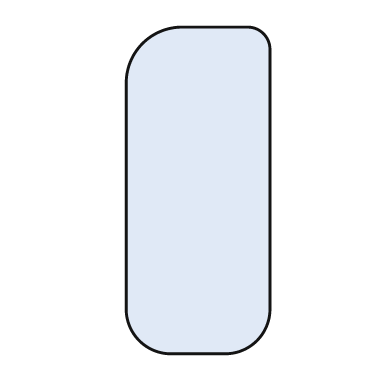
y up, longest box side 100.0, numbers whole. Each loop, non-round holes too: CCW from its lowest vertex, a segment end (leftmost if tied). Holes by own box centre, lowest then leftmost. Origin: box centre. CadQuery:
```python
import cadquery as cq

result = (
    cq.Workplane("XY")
    .moveTo(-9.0, -50.0)
    .lineTo(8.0, -50.0)
    .threePointArc((18.0, -46.0), (22.0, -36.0))
    .lineTo(22.0, 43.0)
    .threePointArc((20.0, 48.0), (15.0, 50.0))
    .lineTo(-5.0, 50.0)
    .threePointArc((-17.0, 45.0), (-22.0, 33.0))
    .lineTo(-22.0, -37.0)
    .threePointArc((-18.0, -46.0), (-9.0, -50.0))
    .close()
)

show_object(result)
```